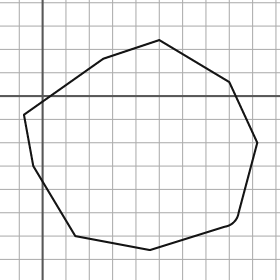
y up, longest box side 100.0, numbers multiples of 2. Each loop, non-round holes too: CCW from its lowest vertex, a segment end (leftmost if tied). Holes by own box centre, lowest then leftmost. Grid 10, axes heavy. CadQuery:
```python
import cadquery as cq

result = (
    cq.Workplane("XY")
    .moveTo(46.0, -66.0)
    .lineTo(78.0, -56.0)
    .threePointArc((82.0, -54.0), (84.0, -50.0))
    .lineTo(92.0, -20.0)
    .lineTo(80.0, 6.0)
    .lineTo(50.0, 24.0)
    .lineTo(26.0, 16.0)
    .lineTo(-8.0, -8.0)
    .lineTo(-4.0, -30.0)
    .lineTo(14.0, -60.0)
    .close()
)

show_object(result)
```